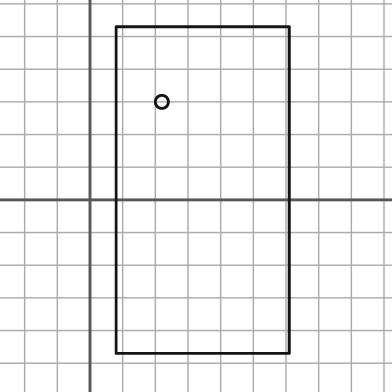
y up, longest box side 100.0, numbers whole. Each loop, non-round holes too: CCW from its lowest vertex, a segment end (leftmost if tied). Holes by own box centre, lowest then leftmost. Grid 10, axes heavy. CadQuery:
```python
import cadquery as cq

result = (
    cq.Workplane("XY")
    .moveTo(8.0, -47.0)
    .lineTo(61.0, -47.0)
    .lineTo(61.0, 53.0)
    .lineTo(8.0, 53.0)
    .close()
    .moveTo(22.0, 30.0)
    .circle(2.0)
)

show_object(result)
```